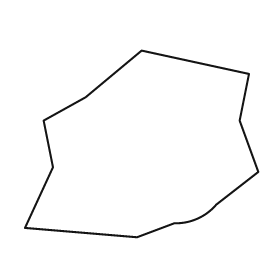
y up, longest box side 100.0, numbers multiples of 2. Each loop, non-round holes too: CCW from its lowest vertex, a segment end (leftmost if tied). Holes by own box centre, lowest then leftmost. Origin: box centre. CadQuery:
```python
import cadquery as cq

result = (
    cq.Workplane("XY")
    .moveTo(-2.0, -40.0)
    .lineTo(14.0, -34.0)
    .threePointArc((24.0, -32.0), (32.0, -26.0))
    .lineTo(50.0, -12.0)
    .lineTo(42.0, 10.0)
    .lineTo(46.0, 30.0)
    .lineTo(0.0, 40.0)
    .lineTo(-24.0, 20.0)
    .lineTo(-42.0, 10.0)
    .lineTo(-38.0, -10.0)
    .lineTo(-50.0, -36.0)
    .close()
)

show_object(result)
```